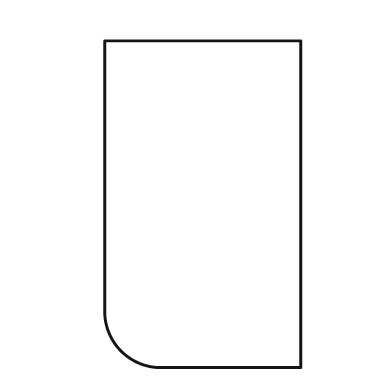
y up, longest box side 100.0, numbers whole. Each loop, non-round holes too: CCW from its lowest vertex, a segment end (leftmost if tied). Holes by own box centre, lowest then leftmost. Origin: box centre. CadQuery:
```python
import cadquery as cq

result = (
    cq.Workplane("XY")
    .moveTo(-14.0, -50.0)
    .lineTo(30.0, -50.0)
    .lineTo(30.0, 50.0)
    .lineTo(-30.0, 50.0)
    .lineTo(-30.0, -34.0)
    .threePointArc((-25.0, -45.0), (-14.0, -50.0))
    .close()
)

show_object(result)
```